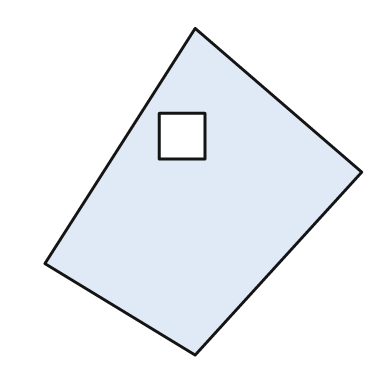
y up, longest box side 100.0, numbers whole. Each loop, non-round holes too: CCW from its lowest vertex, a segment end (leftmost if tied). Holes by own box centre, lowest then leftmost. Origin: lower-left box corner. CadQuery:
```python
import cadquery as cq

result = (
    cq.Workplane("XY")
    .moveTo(46.0, 0.0)
    .lineTo(97.0, 56.0)
    .lineTo(46.0, 100.0)
    .lineTo(0.0, 28.0)
    .close()
    .moveTo(35.0, 60.0)
    .lineTo(49.0, 60.0)
    .lineTo(49.0, 74.0)
    .lineTo(35.0, 74.0)
    .close()
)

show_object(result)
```